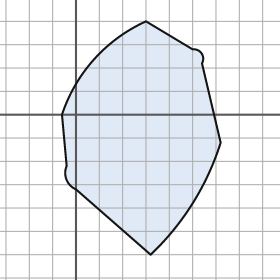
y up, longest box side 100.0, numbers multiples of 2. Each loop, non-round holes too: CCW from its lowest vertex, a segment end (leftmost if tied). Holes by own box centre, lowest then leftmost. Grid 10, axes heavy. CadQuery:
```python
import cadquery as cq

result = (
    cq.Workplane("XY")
    .moveTo(32.0, -60.0)
    .threePointArc((50.0, -38.0), (62.0, -12.0))
    .lineTo(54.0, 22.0)
    .threePointArc((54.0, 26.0), (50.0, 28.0))
    .lineTo(30.0, 40.0)
    .threePointArc((8.0, 24.0), (-6.0, 0.0))
    .lineTo(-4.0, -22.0)
    .threePointArc((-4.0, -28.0), (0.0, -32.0))
    .close()
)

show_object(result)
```